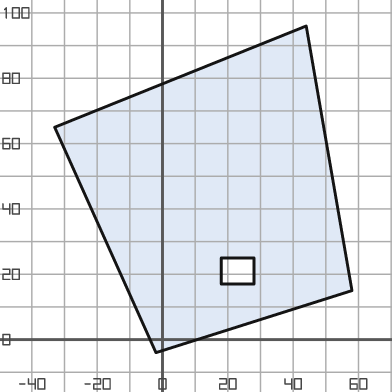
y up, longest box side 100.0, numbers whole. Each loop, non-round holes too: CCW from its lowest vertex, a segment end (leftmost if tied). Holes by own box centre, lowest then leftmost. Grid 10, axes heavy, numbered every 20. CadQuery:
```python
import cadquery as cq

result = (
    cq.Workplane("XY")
    .moveTo(-2.0, -4.0)
    .lineTo(58.0, 15.0)
    .lineTo(44.0, 96.0)
    .lineTo(-33.0, 65.0)
    .close()
    .moveTo(18.0, 17.0)
    .lineTo(28.0, 17.0)
    .lineTo(28.0, 25.0)
    .lineTo(18.0, 25.0)
    .close()
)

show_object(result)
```